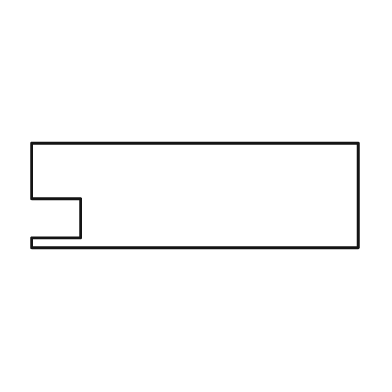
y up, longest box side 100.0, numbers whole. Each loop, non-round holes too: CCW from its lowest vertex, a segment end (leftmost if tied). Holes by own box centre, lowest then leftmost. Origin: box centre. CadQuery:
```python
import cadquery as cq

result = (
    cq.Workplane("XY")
    .moveTo(-50.0, -16.0)
    .lineTo(50.0, -16.0)
    .lineTo(50.0, 16.0)
    .lineTo(-50.0, 16.0)
    .lineTo(-50.0, -1.0)
    .lineTo(-35.0, -1.0)
    .lineTo(-35.0, -13.0)
    .lineTo(-50.0, -13.0)
    .close()
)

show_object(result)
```